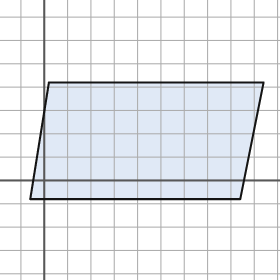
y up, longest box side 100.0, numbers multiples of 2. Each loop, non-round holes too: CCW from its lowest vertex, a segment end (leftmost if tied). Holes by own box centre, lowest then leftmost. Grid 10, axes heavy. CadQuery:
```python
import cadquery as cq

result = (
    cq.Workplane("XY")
    .moveTo(-6.0, -8.0)
    .lineTo(84.0, -8.0)
    .lineTo(94.0, 42.0)
    .lineTo(2.0, 42.0)
    .close()
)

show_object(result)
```